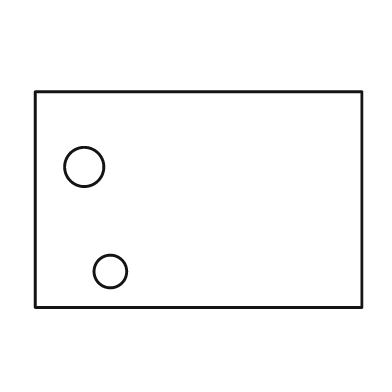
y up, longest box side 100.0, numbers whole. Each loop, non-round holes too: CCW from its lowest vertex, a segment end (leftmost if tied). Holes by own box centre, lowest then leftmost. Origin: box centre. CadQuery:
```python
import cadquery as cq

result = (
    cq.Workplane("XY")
    .moveTo(-50.0, -33.0)
    .lineTo(50.0, -33.0)
    .lineTo(50.0, 33.0)
    .lineTo(-50.0, 33.0)
    .close()
    .moveTo(-27.0, -22.0)
    .circle(5.0)
    .moveTo(-35.0, 10.0)
    .circle(6.0)
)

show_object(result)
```